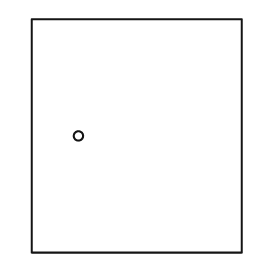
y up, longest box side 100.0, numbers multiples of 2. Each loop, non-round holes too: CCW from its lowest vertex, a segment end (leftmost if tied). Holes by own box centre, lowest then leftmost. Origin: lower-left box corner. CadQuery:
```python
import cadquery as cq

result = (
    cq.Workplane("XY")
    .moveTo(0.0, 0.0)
    .lineTo(90.0, 0.0)
    .lineTo(90.0, 100.0)
    .lineTo(0.0, 100.0)
    .close()
    .moveTo(20.0, 50.0)
    .circle(2.0)
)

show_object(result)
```